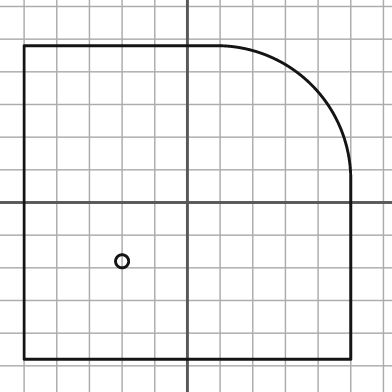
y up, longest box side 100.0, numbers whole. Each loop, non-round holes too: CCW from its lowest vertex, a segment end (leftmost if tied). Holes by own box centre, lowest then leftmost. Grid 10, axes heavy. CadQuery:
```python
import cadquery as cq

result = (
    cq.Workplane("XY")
    .moveTo(-50.0, -48.0)
    .lineTo(50.0, -48.0)
    .lineTo(50.0, 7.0)
    .threePointArc((38.0, 36.0), (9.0, 48.0))
    .lineTo(-50.0, 48.0)
    .close()
    .moveTo(-20.0, -18.0)
    .circle(2.0)
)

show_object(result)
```